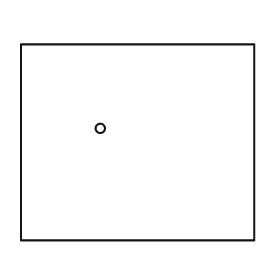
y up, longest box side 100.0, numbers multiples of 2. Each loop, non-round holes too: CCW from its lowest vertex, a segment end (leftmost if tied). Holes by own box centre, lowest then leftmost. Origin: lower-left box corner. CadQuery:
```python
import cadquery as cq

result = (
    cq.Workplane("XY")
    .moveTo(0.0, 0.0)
    .lineTo(100.0, 0.0)
    .lineTo(100.0, 84.0)
    .lineTo(0.0, 84.0)
    .close()
    .moveTo(34.0, 48.0)
    .circle(2.0)
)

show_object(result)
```